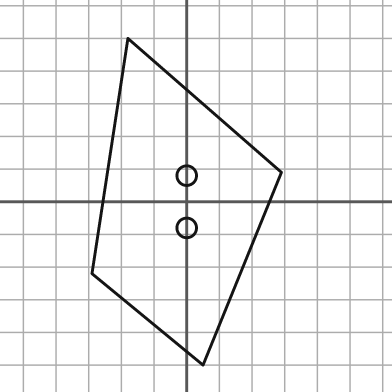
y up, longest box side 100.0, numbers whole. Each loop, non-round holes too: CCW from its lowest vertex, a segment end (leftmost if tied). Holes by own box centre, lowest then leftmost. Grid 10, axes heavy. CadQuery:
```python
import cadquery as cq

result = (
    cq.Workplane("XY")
    .moveTo(5.0, -50.0)
    .lineTo(29.0, 9.0)
    .lineTo(-18.0, 50.0)
    .lineTo(-29.0, -22.0)
    .close()
    .moveTo(0.0, -8.0)
    .circle(3.0)
    .moveTo(0.0, 8.0)
    .circle(3.0)
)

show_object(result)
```